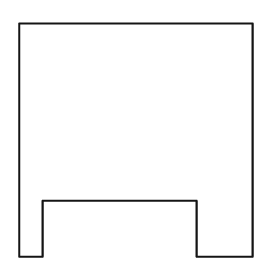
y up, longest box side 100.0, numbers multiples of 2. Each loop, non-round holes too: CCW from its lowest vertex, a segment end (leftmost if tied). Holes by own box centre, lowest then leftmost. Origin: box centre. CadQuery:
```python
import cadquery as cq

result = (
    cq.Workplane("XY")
    .moveTo(-50.0, -50.0)
    .lineTo(-40.0, -50.0)
    .lineTo(-40.0, -26.0)
    .lineTo(26.0, -26.0)
    .lineTo(26.0, -50.0)
    .lineTo(50.0, -50.0)
    .lineTo(50.0, 50.0)
    .lineTo(-50.0, 50.0)
    .close()
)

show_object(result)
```